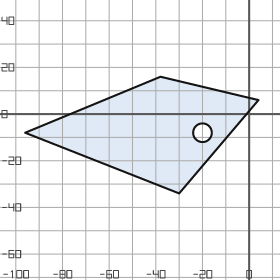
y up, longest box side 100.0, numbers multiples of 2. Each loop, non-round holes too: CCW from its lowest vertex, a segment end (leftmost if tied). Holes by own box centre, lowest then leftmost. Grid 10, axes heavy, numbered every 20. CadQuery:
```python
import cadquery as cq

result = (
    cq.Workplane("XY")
    .moveTo(-30.0, -34.0)
    .lineTo(4.0, 6.0)
    .lineTo(-38.0, 16.0)
    .lineTo(-96.0, -8.0)
    .close()
    .moveTo(-20.0, -8.0)
    .circle(4.0)
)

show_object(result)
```